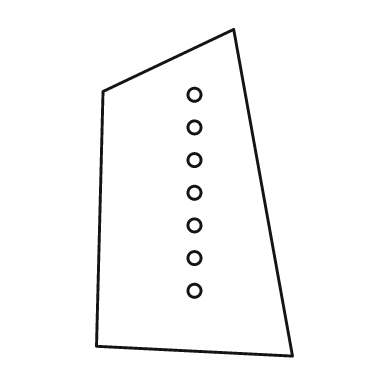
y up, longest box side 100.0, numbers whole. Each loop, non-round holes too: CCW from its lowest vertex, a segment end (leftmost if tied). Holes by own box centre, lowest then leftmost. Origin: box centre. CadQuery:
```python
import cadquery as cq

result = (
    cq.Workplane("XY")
    .moveTo(30.0, -50.0)
    .lineTo(12.0, 50.0)
    .lineTo(-28.0, 31.0)
    .lineTo(-30.0, -47.0)
    .close()
    .moveTo(0.0, -30.0)
    .circle(2.0)
    .moveTo(0.0, -20.0)
    .circle(2.0)
    .moveTo(0.0, -10.0)
    .circle(2.0)
    .moveTo(0.0, 0.0)
    .circle(2.0)
    .moveTo(0.0, 10.0)
    .circle(2.0)
    .moveTo(0.0, 20.0)
    .circle(2.0)
    .moveTo(0.0, 30.0)
    .circle(2.0)
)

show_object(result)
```